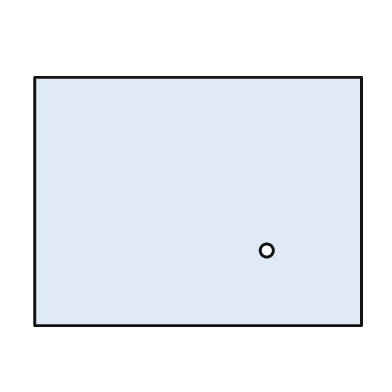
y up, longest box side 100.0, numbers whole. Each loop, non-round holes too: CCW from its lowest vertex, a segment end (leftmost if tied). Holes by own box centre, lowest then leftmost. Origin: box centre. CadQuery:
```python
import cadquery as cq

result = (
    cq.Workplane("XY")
    .moveTo(-50.0, -38.0)
    .lineTo(50.0, -38.0)
    .lineTo(50.0, 38.0)
    .lineTo(-50.0, 38.0)
    .close()
    .moveTo(21.0, -15.0)
    .circle(2.0)
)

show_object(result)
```